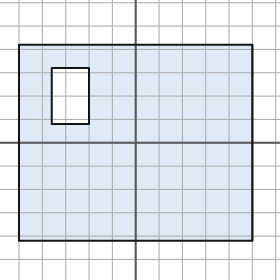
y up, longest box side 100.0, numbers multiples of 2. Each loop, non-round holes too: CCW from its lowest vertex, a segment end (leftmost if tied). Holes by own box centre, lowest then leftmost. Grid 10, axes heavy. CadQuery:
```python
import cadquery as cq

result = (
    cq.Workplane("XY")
    .moveTo(-50.0, -42.0)
    .lineTo(50.0, -42.0)
    .lineTo(50.0, 42.0)
    .lineTo(-50.0, 42.0)
    .close()
    .moveTo(-36.0, 8.0)
    .lineTo(-20.0, 8.0)
    .lineTo(-20.0, 32.0)
    .lineTo(-36.0, 32.0)
    .close()
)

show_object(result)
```